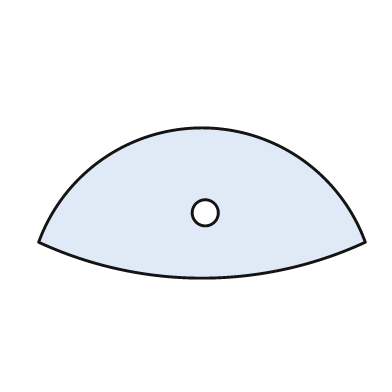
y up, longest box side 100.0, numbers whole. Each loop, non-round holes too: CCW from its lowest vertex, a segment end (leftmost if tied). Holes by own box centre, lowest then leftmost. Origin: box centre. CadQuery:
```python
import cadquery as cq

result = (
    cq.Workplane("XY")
    .moveTo(-50.0, -12.0)
    .threePointArc((0.0, -23.0), (50.0, -12.0))
    .threePointArc((0.0, 23.0), (-50.0, -12.0))
    .close()
    .moveTo(1.0, -3.0)
    .circle(4.0)
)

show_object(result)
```